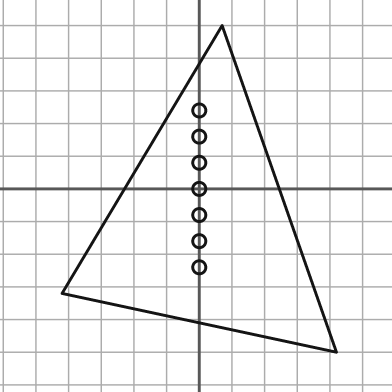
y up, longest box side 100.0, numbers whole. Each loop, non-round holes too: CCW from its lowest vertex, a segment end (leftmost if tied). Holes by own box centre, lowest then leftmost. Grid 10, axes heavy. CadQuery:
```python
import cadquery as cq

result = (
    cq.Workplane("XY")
    .moveTo(42.0, -50.0)
    .lineTo(7.0, 50.0)
    .lineTo(-42.0, -32.0)
    .close()
    .moveTo(0.0, -24.0)
    .circle(2.0)
    .moveTo(0.0, -16.0)
    .circle(2.0)
    .moveTo(0.0, -8.0)
    .circle(2.0)
    .moveTo(0.0, 0.0)
    .circle(2.0)
    .moveTo(0.0, 8.0)
    .circle(2.0)
    .moveTo(0.0, 16.0)
    .circle(2.0)
    .moveTo(0.0, 24.0)
    .circle(2.0)
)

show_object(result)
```